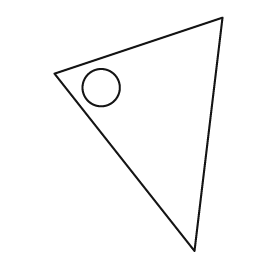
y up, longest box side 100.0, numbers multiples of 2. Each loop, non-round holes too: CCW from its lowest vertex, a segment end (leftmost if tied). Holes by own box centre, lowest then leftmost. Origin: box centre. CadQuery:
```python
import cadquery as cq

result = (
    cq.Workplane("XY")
    .moveTo(24.0, -50.0)
    .lineTo(36.0, 50.0)
    .lineTo(-36.0, 26.0)
    .close()
    .moveTo(-16.0, 20.0)
    .circle(8.0)
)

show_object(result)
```